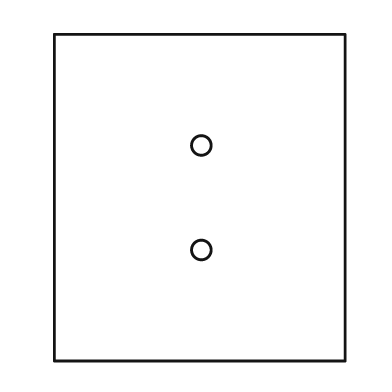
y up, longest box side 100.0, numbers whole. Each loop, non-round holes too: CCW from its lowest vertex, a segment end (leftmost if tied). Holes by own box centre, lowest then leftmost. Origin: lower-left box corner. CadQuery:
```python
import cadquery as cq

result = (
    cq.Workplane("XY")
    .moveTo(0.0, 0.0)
    .lineTo(89.0, 0.0)
    .lineTo(89.0, 100.0)
    .lineTo(0.0, 100.0)
    .close()
    .moveTo(45.0, 34.0)
    .circle(3.0)
    .moveTo(45.0, 66.0)
    .circle(3.0)
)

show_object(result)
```